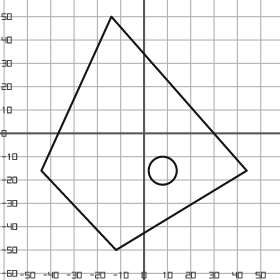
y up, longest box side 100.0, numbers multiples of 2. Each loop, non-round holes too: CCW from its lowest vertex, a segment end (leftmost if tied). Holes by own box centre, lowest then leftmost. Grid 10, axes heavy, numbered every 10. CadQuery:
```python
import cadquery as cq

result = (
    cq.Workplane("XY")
    .moveTo(-12.0, -50.0)
    .lineTo(44.0, -16.0)
    .lineTo(-14.0, 50.0)
    .lineTo(-44.0, -16.0)
    .close()
    .moveTo(8.0, -16.0)
    .circle(6.0)
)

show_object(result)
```